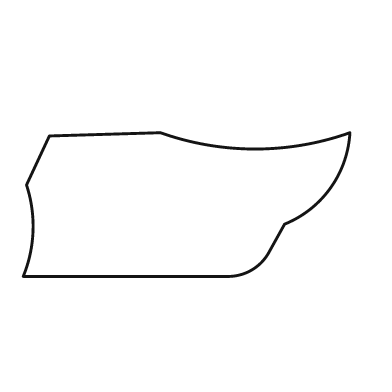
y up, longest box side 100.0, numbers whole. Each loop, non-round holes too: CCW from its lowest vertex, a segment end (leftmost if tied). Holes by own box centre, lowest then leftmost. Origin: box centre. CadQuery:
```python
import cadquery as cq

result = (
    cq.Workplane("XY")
    .moveTo(-50.0, -22.0)
    .lineTo(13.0, -22.0)
    .threePointArc((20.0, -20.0), (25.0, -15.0))
    .lineTo(30.0, -6.0)
    .threePointArc((44.0, 5.0), (50.0, 22.0))
    .threePointArc((21.0, 17.0), (-8.0, 22.0))
    .lineTo(-42.0, 21.0)
    .lineTo(-49.0, 6.0)
    .threePointArc((-47.0, -8.0), (-50.0, -22.0))
    .close()
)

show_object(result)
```